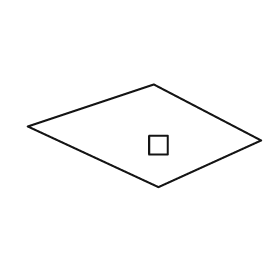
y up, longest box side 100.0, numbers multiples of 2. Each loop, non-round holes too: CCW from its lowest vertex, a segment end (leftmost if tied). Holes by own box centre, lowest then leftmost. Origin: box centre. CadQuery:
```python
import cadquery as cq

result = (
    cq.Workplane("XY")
    .moveTo(6.0, -22.0)
    .lineTo(50.0, -2.0)
    .lineTo(4.0, 22.0)
    .lineTo(-50.0, 4.0)
    .close()
    .moveTo(2.0, -8.0)
    .lineTo(10.0, -8.0)
    .lineTo(10.0, 0.0)
    .lineTo(2.0, 0.0)
    .close()
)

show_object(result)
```